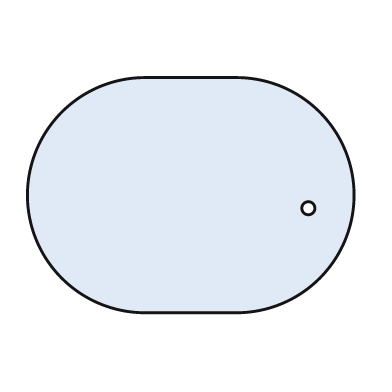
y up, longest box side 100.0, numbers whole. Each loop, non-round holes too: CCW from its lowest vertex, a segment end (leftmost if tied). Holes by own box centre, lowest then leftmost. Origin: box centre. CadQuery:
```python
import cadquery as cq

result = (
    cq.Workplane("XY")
    .moveTo(-14.0, -36.0)
    .lineTo(14.0, -36.0)
    .threePointArc((50.0, 0.0), (14.0, 36.0))
    .lineTo(-14.0, 36.0)
    .threePointArc((-50.0, 0.0), (-14.0, -36.0))
    .close()
    .moveTo(36.0, -4.0)
    .circle(2.0)
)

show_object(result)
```